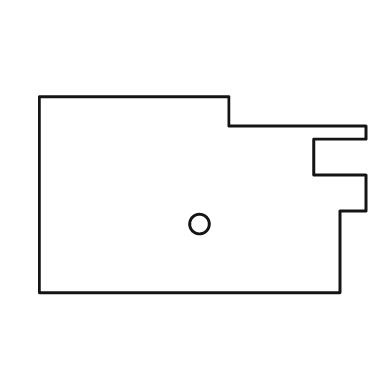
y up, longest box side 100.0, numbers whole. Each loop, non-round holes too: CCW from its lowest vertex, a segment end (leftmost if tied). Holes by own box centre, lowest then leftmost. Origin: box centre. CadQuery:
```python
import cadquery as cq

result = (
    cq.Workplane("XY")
    .moveTo(-50.0, -30.0)
    .lineTo(42.0, -30.0)
    .lineTo(42.0, -5.0)
    .lineTo(50.0, -5.0)
    .lineTo(50.0, 6.0)
    .lineTo(34.0, 6.0)
    .lineTo(34.0, 17.0)
    .lineTo(50.0, 17.0)
    .lineTo(50.0, 21.0)
    .lineTo(8.0, 21.0)
    .lineTo(8.0, 30.0)
    .lineTo(-50.0, 30.0)
    .close()
    .moveTo(-1.0, -9.0)
    .circle(3.0)
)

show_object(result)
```